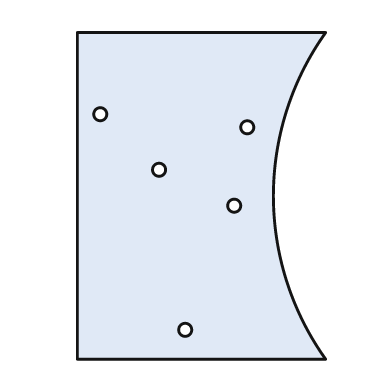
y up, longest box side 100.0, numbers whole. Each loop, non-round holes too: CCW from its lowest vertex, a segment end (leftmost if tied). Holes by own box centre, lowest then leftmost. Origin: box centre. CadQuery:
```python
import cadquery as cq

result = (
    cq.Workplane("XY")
    .moveTo(-38.0, -50.0)
    .lineTo(38.0, -50.0)
    .threePointArc((22.0, 0.0), (38.0, 50.0))
    .lineTo(-38.0, 50.0)
    .close()
    .moveTo(-5.0, -41.0)
    .circle(2.0)
    .moveTo(10.0, -3.0)
    .circle(2.0)
    .moveTo(-13.0, 8.0)
    .circle(2.0)
    .moveTo(14.0, 21.0)
    .circle(2.0)
    .moveTo(-31.0, 25.0)
    .circle(2.0)
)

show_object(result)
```